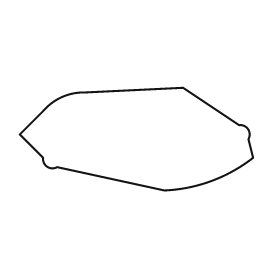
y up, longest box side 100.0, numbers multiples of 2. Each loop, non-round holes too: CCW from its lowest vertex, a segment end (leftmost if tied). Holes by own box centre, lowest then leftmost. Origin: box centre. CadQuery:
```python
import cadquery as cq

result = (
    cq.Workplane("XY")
    .moveTo(12.0, -22.0)
    .threePointArc((32.0, -18.0), (50.0, -8.0))
    .lineTo(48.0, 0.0)
    .threePointArc((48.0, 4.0), (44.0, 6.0))
    .lineTo(20.0, 22.0)
    .lineTo(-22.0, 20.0)
    .threePointArc((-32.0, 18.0), (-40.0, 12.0))
    .lineTo(-50.0, 2.0)
    .lineTo(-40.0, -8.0)
    .threePointArc((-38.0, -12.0), (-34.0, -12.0))
    .close()
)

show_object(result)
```